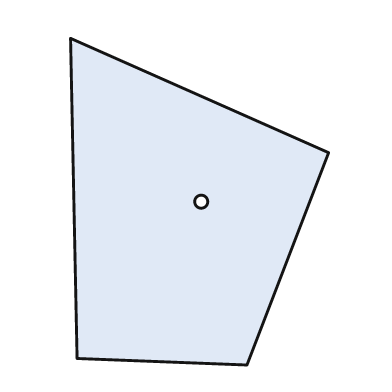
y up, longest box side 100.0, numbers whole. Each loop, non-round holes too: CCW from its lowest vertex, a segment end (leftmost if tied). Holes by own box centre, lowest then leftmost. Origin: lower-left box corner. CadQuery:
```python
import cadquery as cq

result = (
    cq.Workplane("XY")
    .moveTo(54.0, 0.0)
    .lineTo(79.0, 65.0)
    .lineTo(0.0, 100.0)
    .lineTo(2.0, 2.0)
    .close()
    .moveTo(40.0, 50.0)
    .circle(2.0)
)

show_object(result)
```